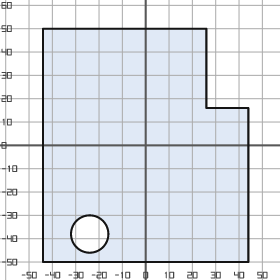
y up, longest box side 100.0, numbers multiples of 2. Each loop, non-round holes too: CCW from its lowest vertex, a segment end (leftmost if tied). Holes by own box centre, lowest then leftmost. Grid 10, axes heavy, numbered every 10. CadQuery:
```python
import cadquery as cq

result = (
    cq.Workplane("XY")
    .moveTo(-44.0, -50.0)
    .lineTo(44.0, -50.0)
    .lineTo(44.0, 16.0)
    .lineTo(26.0, 16.0)
    .lineTo(26.0, 50.0)
    .lineTo(-44.0, 50.0)
    .close()
    .moveTo(-24.0, -38.0)
    .circle(8.0)
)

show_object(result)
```